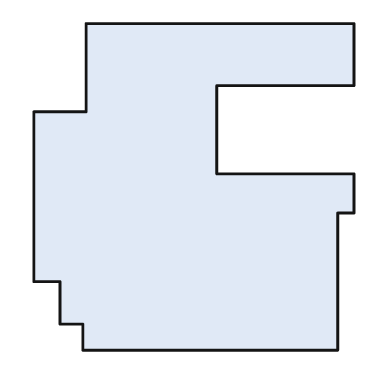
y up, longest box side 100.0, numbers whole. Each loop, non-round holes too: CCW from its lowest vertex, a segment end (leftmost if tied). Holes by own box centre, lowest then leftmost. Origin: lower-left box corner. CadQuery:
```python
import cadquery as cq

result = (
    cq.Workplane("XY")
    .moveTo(15.0, 0.0)
    .lineTo(93.0, 0.0)
    .lineTo(93.0, 42.0)
    .lineTo(98.0, 42.0)
    .lineTo(98.0, 54.0)
    .lineTo(56.0, 54.0)
    .lineTo(56.0, 81.0)
    .lineTo(98.0, 81.0)
    .lineTo(98.0, 100.0)
    .lineTo(16.0, 100.0)
    .lineTo(16.0, 73.0)
    .lineTo(0.0, 73.0)
    .lineTo(0.0, 21.0)
    .lineTo(8.0, 21.0)
    .lineTo(8.0, 8.0)
    .lineTo(15.0, 8.0)
    .close()
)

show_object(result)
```